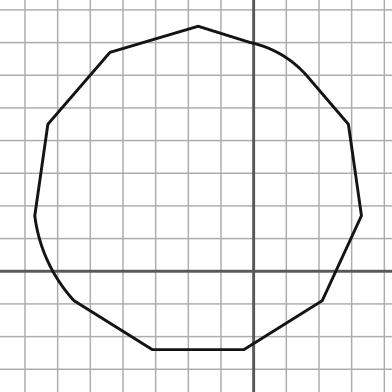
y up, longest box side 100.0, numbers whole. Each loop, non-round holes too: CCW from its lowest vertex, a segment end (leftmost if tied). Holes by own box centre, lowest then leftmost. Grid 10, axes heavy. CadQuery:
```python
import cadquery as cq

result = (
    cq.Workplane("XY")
    .moveTo(-31.0, -24.0)
    .lineTo(-3.0, -24.0)
    .lineTo(21.0, -9.0)
    .lineTo(33.0, 17.0)
    .lineTo(29.0, 45.0)
    .lineTo(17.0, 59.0)
    .threePointArc((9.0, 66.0), (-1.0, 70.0))
    .lineTo(-17.0, 75.0)
    .lineTo(-44.0, 67.0)
    .lineTo(-63.0, 45.0)
    .lineTo(-67.0, 17.0)
    .threePointArc((-63.0, 3.0), (-55.0, -9.0))
    .close()
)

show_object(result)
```